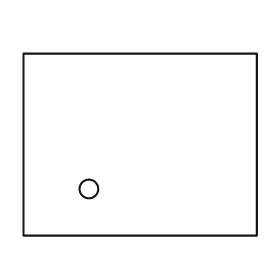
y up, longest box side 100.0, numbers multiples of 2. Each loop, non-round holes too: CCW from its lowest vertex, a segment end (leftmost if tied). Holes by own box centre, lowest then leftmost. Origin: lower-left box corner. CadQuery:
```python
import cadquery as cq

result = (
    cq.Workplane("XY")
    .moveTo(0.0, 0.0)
    .lineTo(100.0, 0.0)
    .lineTo(100.0, 78.0)
    .lineTo(0.0, 78.0)
    .close()
    .moveTo(28.0, 20.0)
    .circle(4.0)
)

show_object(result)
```